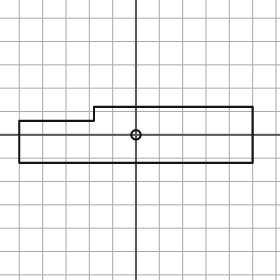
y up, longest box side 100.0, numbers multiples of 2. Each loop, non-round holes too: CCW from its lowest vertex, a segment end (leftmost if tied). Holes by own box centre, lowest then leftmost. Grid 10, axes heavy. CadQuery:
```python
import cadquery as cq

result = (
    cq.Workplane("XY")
    .moveTo(-50.0, -12.0)
    .lineTo(50.0, -12.0)
    .lineTo(50.0, 12.0)
    .lineTo(-18.0, 12.0)
    .lineTo(-18.0, 6.0)
    .lineTo(-50.0, 6.0)
    .close()
    .moveTo(0.0, 0.0)
    .circle(2.0)
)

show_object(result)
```